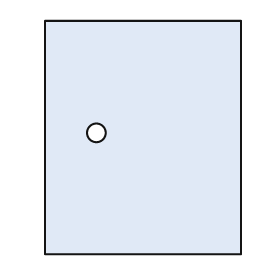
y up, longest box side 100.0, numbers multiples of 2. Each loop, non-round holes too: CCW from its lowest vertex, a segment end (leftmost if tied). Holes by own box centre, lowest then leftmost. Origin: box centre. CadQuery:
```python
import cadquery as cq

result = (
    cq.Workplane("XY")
    .moveTo(-42.0, -50.0)
    .lineTo(42.0, -50.0)
    .lineTo(42.0, 50.0)
    .lineTo(-42.0, 50.0)
    .close()
    .moveTo(-20.0, 2.0)
    .circle(4.0)
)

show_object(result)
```